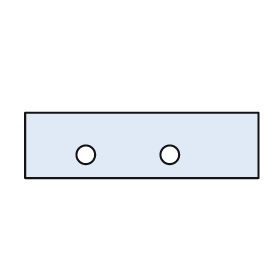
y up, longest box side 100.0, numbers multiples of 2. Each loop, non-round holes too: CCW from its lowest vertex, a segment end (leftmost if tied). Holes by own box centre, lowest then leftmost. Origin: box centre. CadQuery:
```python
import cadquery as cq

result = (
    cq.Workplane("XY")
    .moveTo(-50.0, -14.0)
    .lineTo(50.0, -14.0)
    .lineTo(50.0, 14.0)
    .lineTo(-50.0, 14.0)
    .close()
    .moveTo(-24.0, -4.0)
    .circle(4.0)
    .moveTo(12.0, -4.0)
    .circle(4.0)
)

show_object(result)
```